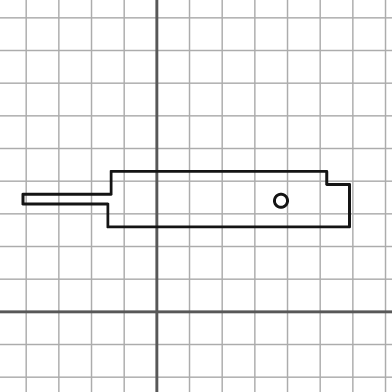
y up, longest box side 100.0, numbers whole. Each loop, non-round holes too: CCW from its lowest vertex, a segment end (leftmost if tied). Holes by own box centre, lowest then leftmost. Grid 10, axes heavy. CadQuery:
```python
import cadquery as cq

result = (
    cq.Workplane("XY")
    .moveTo(-15.0, 26.0)
    .lineTo(59.0, 26.0)
    .lineTo(59.0, 39.0)
    .lineTo(52.0, 39.0)
    .lineTo(52.0, 43.0)
    .lineTo(-14.0, 43.0)
    .lineTo(-14.0, 36.0)
    .lineTo(-41.0, 36.0)
    .lineTo(-41.0, 33.0)
    .lineTo(-15.0, 33.0)
    .close()
    .moveTo(38.0, 34.0)
    .circle(2.0)
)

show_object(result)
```